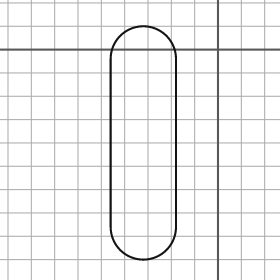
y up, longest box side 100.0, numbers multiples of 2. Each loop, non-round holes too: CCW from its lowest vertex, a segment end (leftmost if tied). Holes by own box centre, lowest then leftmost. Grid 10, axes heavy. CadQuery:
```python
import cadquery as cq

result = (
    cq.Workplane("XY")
    .moveTo(-46.0, -76.0)
    .threePointArc((-32.0, -90.0), (-18.0, -76.0))
    .lineTo(-18.0, -4.0)
    .threePointArc((-32.0, 10.0), (-46.0, -4.0))
    .close()
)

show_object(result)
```